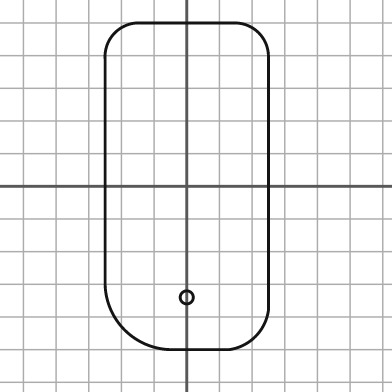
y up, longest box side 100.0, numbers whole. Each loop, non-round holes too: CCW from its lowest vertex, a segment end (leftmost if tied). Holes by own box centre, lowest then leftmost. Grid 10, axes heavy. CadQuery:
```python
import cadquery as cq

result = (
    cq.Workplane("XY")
    .moveTo(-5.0, -50.0)
    .lineTo(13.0, -50.0)
    .threePointArc((21.0, -46.0), (25.0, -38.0))
    .lineTo(25.0, 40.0)
    .threePointArc((22.0, 47.0), (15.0, 50.0))
    .lineTo(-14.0, 50.0)
    .threePointArc((-22.0, 47.0), (-25.0, 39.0))
    .lineTo(-25.0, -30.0)
    .threePointArc((-19.0, -44.0), (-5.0, -50.0))
    .close()
    .moveTo(0.0, -34.0)
    .circle(2.0)
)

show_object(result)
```